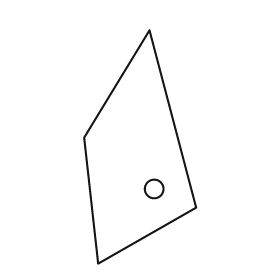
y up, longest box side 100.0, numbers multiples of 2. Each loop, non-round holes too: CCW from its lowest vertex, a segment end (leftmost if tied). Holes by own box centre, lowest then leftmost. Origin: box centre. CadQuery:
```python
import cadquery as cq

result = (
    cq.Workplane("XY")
    .moveTo(-18.0, -50.0)
    .lineTo(24.0, -26.0)
    .lineTo(4.0, 50.0)
    .lineTo(-24.0, 4.0)
    .close()
    .moveTo(6.0, -18.0)
    .circle(4.0)
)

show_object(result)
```